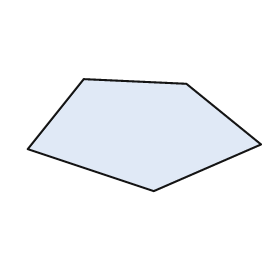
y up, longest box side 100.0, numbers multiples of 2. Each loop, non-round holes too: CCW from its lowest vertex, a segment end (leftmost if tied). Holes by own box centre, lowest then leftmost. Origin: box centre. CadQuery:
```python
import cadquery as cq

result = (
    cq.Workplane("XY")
    .moveTo(4.0, -24.0)
    .lineTo(50.0, -4.0)
    .lineTo(18.0, 22.0)
    .lineTo(-26.0, 24.0)
    .lineTo(-50.0, -6.0)
    .close()
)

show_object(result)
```